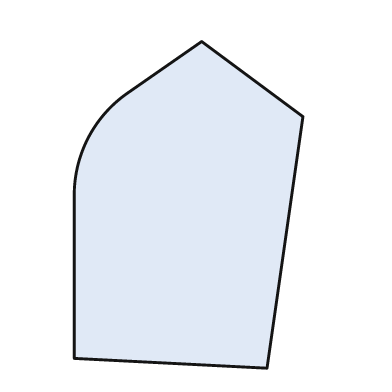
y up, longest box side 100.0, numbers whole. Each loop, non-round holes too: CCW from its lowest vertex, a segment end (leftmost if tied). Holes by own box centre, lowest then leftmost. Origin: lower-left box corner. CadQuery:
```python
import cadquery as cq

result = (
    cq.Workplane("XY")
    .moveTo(59.0, 0.0)
    .lineTo(70.0, 77.0)
    .lineTo(39.0, 100.0)
    .lineTo(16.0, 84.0)
    .threePointArc((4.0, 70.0), (0.0, 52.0))
    .lineTo(0.0, 3.0)
    .close()
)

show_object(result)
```